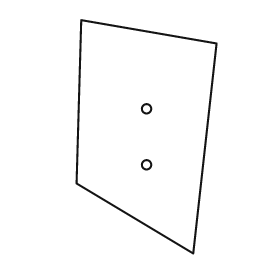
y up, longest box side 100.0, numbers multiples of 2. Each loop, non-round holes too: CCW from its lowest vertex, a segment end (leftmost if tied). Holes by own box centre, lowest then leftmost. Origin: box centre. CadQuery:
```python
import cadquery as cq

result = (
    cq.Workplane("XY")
    .moveTo(20.0, -50.0)
    .lineTo(30.0, 40.0)
    .lineTo(-28.0, 50.0)
    .lineTo(-30.0, -20.0)
    .close()
    .moveTo(0.0, -12.0)
    .circle(2.0)
    .moveTo(0.0, 12.0)
    .circle(2.0)
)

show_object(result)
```